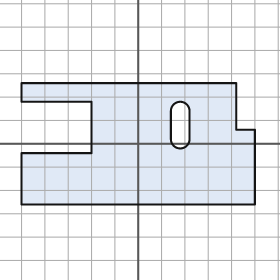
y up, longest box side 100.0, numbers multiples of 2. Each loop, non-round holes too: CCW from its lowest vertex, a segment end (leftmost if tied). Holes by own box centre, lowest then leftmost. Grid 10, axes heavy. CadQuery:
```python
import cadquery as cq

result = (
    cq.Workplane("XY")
    .moveTo(-50.0, -26.0)
    .lineTo(50.0, -26.0)
    .lineTo(50.0, 6.0)
    .lineTo(42.0, 6.0)
    .lineTo(42.0, 26.0)
    .lineTo(-50.0, 26.0)
    .lineTo(-50.0, 18.0)
    .lineTo(-20.0, 18.0)
    .lineTo(-20.0, -4.0)
    .lineTo(-50.0, -4.0)
    .close()
    .moveTo(14.0, 2.0)
    .threePointArc((18.0, -2.0), (22.0, 2.0))
    .lineTo(22.0, 14.0)
    .threePointArc((18.0, 18.0), (14.0, 14.0))
    .close()
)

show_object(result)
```